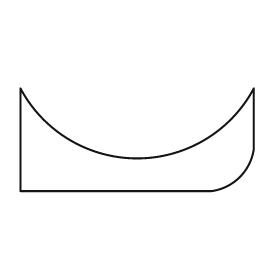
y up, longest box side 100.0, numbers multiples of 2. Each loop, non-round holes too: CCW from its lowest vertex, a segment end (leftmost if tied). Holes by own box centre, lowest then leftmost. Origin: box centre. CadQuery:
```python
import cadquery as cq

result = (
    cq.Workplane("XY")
    .moveTo(-50.0, -22.0)
    .lineTo(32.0, -22.0)
    .threePointArc((44.0, -16.0), (50.0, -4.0))
    .lineTo(50.0, 22.0)
    .threePointArc((0.0, -8.0), (-50.0, 22.0))
    .close()
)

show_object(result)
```